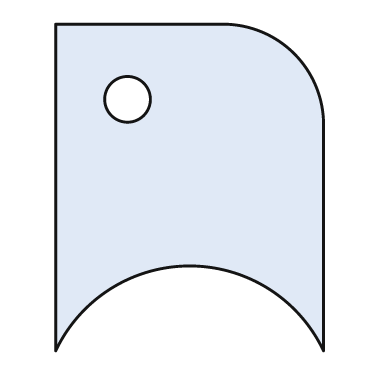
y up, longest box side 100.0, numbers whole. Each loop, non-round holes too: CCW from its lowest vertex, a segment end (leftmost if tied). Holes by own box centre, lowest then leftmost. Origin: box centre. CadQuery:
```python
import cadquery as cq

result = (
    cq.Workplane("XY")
    .moveTo(-41.0, -50.0)
    .threePointArc((0.0, -24.0), (41.0, -50.0))
    .lineTo(41.0, 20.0)
    .threePointArc((32.0, 41.0), (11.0, 50.0))
    .lineTo(-41.0, 50.0)
    .close()
    .moveTo(-19.0, 27.0)
    .circle(7.0)
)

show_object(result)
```